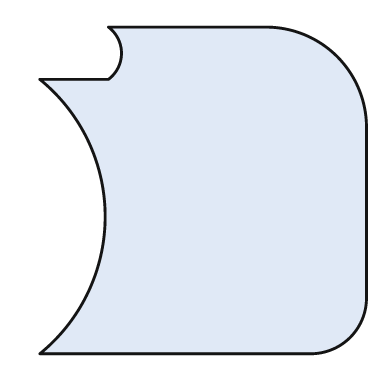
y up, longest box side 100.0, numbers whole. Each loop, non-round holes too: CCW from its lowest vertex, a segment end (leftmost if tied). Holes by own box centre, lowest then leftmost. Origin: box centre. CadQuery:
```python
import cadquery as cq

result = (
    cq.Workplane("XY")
    .moveTo(-50.0, -50.0)
    .lineTo(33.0, -50.0)
    .threePointArc((45.0, -45.0), (50.0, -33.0))
    .lineTo(50.0, 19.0)
    .threePointArc((41.0, 41.0), (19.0, 50.0))
    .lineTo(-29.0, 50.0)
    .threePointArc((-25.0, 42.0), (-29.0, 34.0))
    .lineTo(-50.0, 34.0)
    .threePointArc((-30.0, -8.0), (-50.0, -50.0))
    .close()
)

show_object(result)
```